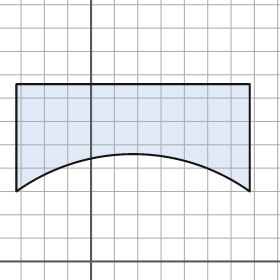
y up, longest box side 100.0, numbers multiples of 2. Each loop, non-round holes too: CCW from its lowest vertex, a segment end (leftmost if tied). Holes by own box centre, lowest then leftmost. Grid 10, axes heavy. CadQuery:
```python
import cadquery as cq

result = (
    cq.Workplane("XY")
    .moveTo(-32.0, 30.0)
    .threePointArc((18.0, 46.0), (68.0, 30.0))
    .lineTo(68.0, 76.0)
    .lineTo(-32.0, 76.0)
    .close()
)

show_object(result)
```